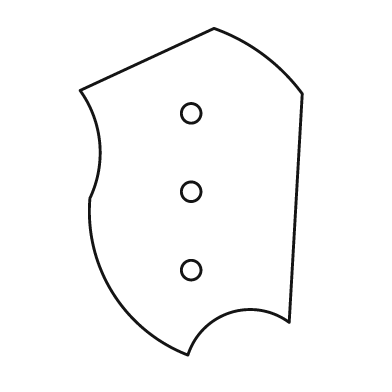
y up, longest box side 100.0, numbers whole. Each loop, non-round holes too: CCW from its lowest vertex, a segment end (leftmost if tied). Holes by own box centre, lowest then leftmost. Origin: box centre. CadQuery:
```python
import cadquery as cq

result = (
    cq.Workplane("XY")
    .moveTo(-1.0, -50.0)
    .threePointArc((12.0, -37.0), (30.0, -40.0))
    .lineTo(34.0, 30.0)
    .threePointArc((22.0, 42.0), (7.0, 50.0))
    .lineTo(-34.0, 31.0)
    .threePointArc((-28.0, 15.0), (-31.0, -2.0))
    .threePointArc((-24.0, -31.0), (-1.0, -50.0))
    .close()
    .moveTo(0.0, -24.0)
    .circle(3.0)
    .moveTo(0.0, 0.0)
    .circle(3.0)
    .moveTo(0.0, 24.0)
    .circle(3.0)
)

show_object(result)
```